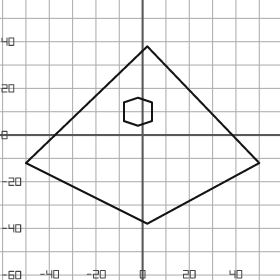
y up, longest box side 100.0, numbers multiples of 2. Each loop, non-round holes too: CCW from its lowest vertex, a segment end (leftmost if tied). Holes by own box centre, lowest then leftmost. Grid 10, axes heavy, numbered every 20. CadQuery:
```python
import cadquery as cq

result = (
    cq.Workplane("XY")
    .moveTo(2.0, -38.0)
    .lineTo(50.0, -12.0)
    .lineTo(2.0, 38.0)
    .lineTo(-50.0, -12.0)
    .close()
    .moveTo(-2.0, 4.0)
    .lineTo(4.0, 6.0)
    .lineTo(4.0, 14.0)
    .lineTo(-2.0, 16.0)
    .lineTo(-8.0, 14.0)
    .lineTo(-8.0, 6.0)
    .close()
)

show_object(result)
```